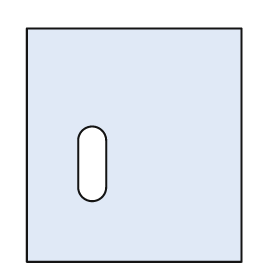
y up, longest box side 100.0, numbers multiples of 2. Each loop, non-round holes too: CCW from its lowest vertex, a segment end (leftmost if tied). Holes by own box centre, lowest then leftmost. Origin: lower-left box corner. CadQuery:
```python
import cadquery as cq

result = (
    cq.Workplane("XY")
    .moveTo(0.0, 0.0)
    .lineTo(92.0, 0.0)
    .lineTo(92.0, 100.0)
    .lineTo(0.0, 100.0)
    .close()
    .moveTo(22.0, 32.0)
    .threePointArc((28.0, 26.0), (34.0, 32.0))
    .lineTo(34.0, 52.0)
    .threePointArc((28.0, 58.0), (22.0, 52.0))
    .close()
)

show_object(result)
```